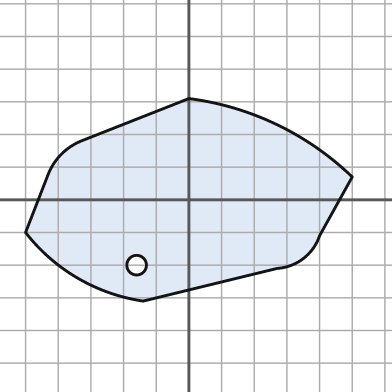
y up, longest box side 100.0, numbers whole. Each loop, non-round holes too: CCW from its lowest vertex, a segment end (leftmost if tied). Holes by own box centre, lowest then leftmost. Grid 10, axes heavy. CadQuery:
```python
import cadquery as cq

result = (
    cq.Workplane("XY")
    .moveTo(-14.0, -31.0)
    .lineTo(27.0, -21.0)
    .threePointArc((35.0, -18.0), (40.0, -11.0))
    .lineTo(50.0, 7.0)
    .threePointArc((27.0, 23.0), (0.0, 31.0))
    .lineTo(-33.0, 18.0)
    .threePointArc((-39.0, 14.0), (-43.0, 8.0))
    .lineTo(-50.0, -10.0)
    .threePointArc((-34.0, -24.0), (-14.0, -31.0))
    .close()
    .moveTo(-16.0, -20.0)
    .circle(3.0)
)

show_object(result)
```